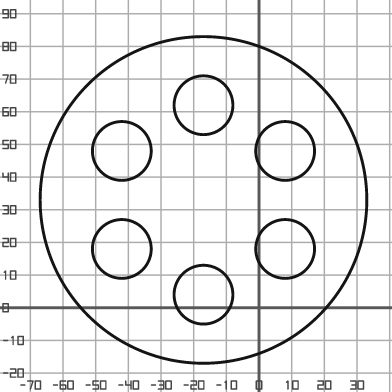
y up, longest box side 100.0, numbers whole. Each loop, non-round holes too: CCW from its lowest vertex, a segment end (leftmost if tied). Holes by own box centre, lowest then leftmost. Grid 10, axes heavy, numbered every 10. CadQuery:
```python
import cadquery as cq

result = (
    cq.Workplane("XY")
    .moveTo(-17.0, 33.0)
    .circle(50.0)
    .moveTo(-17.0, 4.0)
    .circle(9.0)
    .moveTo(-42.0, 18.0)
    .circle(9.0)
    .moveTo(8.0, 18.0)
    .circle(9.0)
    .moveTo(-42.0, 48.0)
    .circle(9.0)
    .moveTo(8.0, 48.0)
    .circle(9.0)
    .moveTo(-17.0, 62.0)
    .circle(9.0)
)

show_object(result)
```